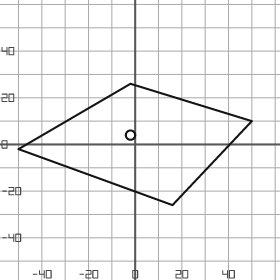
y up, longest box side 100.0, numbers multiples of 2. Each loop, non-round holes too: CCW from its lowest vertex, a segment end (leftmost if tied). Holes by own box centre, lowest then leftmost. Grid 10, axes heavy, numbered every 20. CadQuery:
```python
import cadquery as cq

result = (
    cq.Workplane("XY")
    .moveTo(16.0, -26.0)
    .lineTo(50.0, 10.0)
    .lineTo(-2.0, 26.0)
    .lineTo(-50.0, -2.0)
    .close()
    .moveTo(-2.0, 4.0)
    .circle(2.0)
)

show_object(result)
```